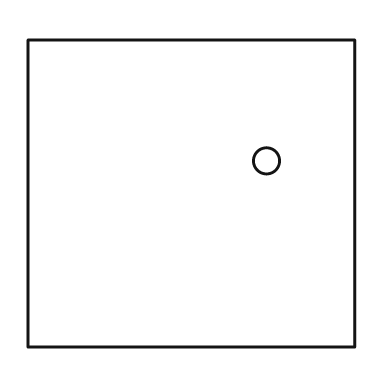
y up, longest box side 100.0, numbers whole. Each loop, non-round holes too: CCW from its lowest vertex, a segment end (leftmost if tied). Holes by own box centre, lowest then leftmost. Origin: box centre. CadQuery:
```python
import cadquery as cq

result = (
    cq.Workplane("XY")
    .moveTo(-50.0, -47.0)
    .lineTo(50.0, -47.0)
    .lineTo(50.0, 47.0)
    .lineTo(-50.0, 47.0)
    .close()
    .moveTo(23.0, 10.0)
    .circle(4.0)
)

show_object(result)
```